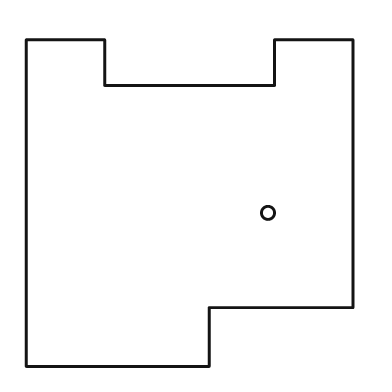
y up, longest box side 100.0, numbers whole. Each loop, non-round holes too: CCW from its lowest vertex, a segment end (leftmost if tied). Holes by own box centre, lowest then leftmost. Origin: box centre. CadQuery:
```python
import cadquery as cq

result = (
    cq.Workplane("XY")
    .moveTo(-50.0, -50.0)
    .lineTo(6.0, -50.0)
    .lineTo(6.0, -32.0)
    .lineTo(50.0, -32.0)
    .lineTo(50.0, 50.0)
    .lineTo(26.0, 50.0)
    .lineTo(26.0, 36.0)
    .lineTo(-26.0, 36.0)
    .lineTo(-26.0, 50.0)
    .lineTo(-50.0, 50.0)
    .close()
    .moveTo(24.0, -3.0)
    .circle(2.0)
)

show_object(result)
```